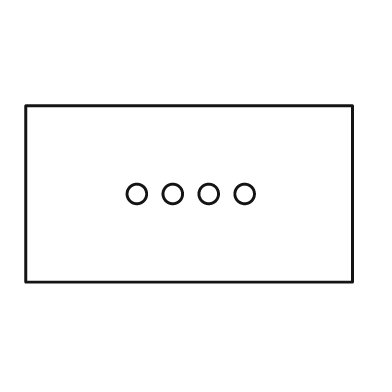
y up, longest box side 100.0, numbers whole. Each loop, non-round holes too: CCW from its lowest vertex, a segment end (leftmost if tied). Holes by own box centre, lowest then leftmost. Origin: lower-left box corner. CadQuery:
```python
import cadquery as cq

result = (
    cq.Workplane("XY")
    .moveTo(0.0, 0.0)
    .lineTo(100.0, 0.0)
    .lineTo(100.0, 54.0)
    .lineTo(0.0, 54.0)
    .close()
    .moveTo(34.0, 27.0)
    .circle(3.0)
    .moveTo(45.0, 27.0)
    .circle(3.0)
    .moveTo(56.0, 27.0)
    .circle(3.0)
    .moveTo(67.0, 27.0)
    .circle(3.0)
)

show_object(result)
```